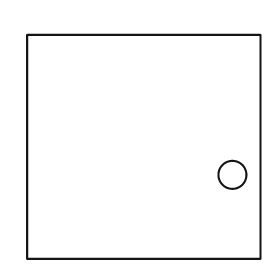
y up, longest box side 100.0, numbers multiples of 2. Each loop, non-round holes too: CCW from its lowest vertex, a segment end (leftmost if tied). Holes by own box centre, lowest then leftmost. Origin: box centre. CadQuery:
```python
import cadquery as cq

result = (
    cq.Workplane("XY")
    .moveTo(-50.0, -48.0)
    .lineTo(50.0, -48.0)
    .lineTo(50.0, 48.0)
    .lineTo(-50.0, 48.0)
    .close()
    .moveTo(38.0, -12.0)
    .circle(6.0)
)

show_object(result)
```